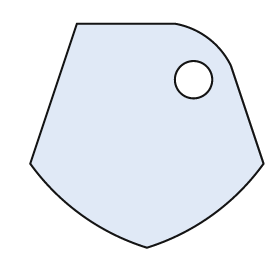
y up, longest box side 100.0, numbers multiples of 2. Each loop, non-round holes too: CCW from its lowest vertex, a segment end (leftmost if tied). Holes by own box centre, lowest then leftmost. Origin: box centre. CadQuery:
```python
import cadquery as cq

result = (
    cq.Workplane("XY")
    .moveTo(0.0, -48.0)
    .threePointArc((28.0, -34.0), (50.0, -12.0))
    .lineTo(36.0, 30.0)
    .threePointArc((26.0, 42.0), (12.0, 48.0))
    .lineTo(-30.0, 48.0)
    .lineTo(-50.0, -12.0)
    .threePointArc((-28.0, -34.0), (0.0, -48.0))
    .close()
    .moveTo(20.0, 24.0)
    .circle(8.0)
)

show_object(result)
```